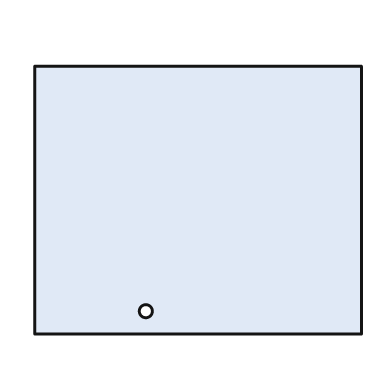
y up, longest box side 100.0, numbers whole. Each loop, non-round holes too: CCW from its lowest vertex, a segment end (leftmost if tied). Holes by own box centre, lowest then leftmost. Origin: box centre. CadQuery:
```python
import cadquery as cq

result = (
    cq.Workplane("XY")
    .moveTo(-50.0, -41.0)
    .lineTo(50.0, -41.0)
    .lineTo(50.0, 41.0)
    .lineTo(-50.0, 41.0)
    .close()
    .moveTo(-16.0, -34.0)
    .circle(2.0)
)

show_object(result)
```